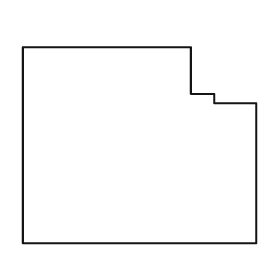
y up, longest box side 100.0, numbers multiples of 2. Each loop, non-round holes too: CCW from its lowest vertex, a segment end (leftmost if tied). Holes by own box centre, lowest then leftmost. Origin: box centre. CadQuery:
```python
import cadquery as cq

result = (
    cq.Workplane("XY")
    .moveTo(-50.0, -42.0)
    .lineTo(50.0, -42.0)
    .lineTo(50.0, 18.0)
    .lineTo(32.0, 18.0)
    .lineTo(32.0, 22.0)
    .lineTo(22.0, 22.0)
    .lineTo(22.0, 42.0)
    .lineTo(-50.0, 42.0)
    .close()
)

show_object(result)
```